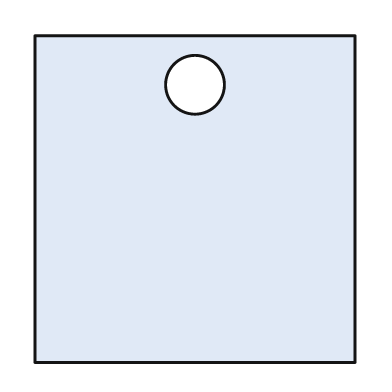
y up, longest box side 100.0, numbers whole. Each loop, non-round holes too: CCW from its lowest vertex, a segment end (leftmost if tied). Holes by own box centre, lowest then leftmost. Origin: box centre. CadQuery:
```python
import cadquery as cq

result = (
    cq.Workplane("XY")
    .moveTo(-49.0, -50.0)
    .lineTo(49.0, -50.0)
    .lineTo(49.0, 50.0)
    .lineTo(-49.0, 50.0)
    .close()
    .moveTo(0.0, 35.0)
    .circle(9.0)
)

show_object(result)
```